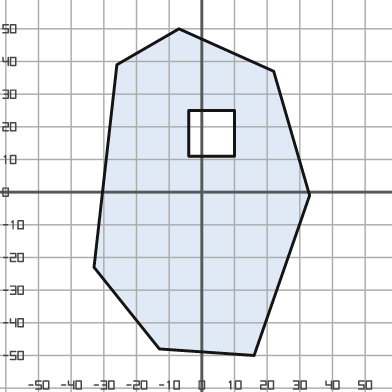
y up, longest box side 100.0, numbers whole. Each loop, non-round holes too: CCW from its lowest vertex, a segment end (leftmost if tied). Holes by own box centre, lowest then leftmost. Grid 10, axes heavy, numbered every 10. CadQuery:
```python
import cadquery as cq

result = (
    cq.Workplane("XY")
    .moveTo(16.0, -50.0)
    .lineTo(33.0, -1.0)
    .lineTo(22.0, 37.0)
    .lineTo(-7.0, 50.0)
    .lineTo(-26.0, 39.0)
    .lineTo(-33.0, -23.0)
    .lineTo(-13.0, -48.0)
    .close()
    .moveTo(-4.0, 11.0)
    .lineTo(10.0, 11.0)
    .lineTo(10.0, 25.0)
    .lineTo(-4.0, 25.0)
    .close()
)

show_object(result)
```